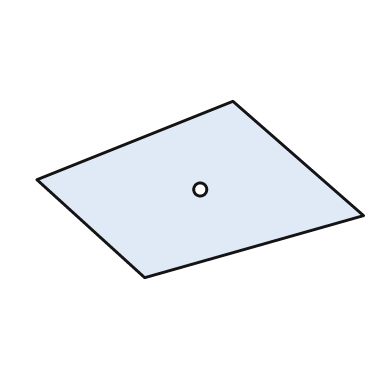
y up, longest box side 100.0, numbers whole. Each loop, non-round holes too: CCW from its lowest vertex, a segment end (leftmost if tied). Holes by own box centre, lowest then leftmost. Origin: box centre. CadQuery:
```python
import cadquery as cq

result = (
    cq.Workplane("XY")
    .moveTo(-17.0, -27.0)
    .lineTo(50.0, -8.0)
    .lineTo(10.0, 27.0)
    .lineTo(-50.0, 3.0)
    .close()
    .moveTo(0.0, 0.0)
    .circle(2.0)
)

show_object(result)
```